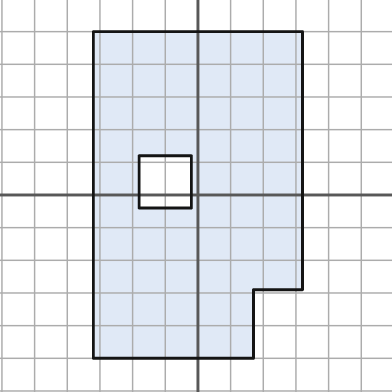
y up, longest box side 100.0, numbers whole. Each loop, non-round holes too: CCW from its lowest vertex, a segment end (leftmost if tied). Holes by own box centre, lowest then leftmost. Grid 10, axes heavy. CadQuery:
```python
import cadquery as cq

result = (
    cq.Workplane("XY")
    .moveTo(-32.0, -50.0)
    .lineTo(17.0, -50.0)
    .lineTo(17.0, -29.0)
    .lineTo(32.0, -29.0)
    .lineTo(32.0, 50.0)
    .lineTo(-32.0, 50.0)
    .close()
    .moveTo(-18.0, -4.0)
    .lineTo(-2.0, -4.0)
    .lineTo(-2.0, 12.0)
    .lineTo(-18.0, 12.0)
    .close()
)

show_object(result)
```